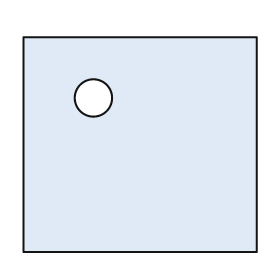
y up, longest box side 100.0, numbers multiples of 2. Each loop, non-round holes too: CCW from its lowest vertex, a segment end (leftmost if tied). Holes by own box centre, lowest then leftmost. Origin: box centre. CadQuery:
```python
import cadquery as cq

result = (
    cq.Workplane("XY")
    .moveTo(-50.0, -46.0)
    .lineTo(50.0, -46.0)
    .lineTo(50.0, 46.0)
    .lineTo(-50.0, 46.0)
    .close()
    .moveTo(-20.0, 20.0)
    .circle(8.0)
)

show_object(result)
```